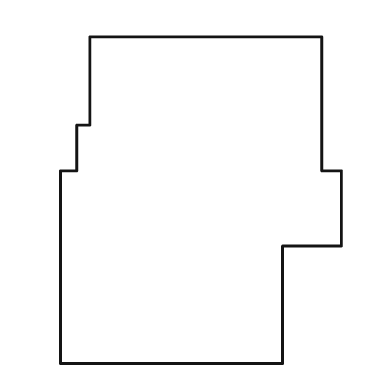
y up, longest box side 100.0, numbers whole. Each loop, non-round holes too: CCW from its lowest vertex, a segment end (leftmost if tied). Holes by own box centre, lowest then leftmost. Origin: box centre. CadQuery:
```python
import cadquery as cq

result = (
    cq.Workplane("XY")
    .moveTo(-43.0, -50.0)
    .lineTo(25.0, -50.0)
    .lineTo(25.0, -14.0)
    .lineTo(43.0, -14.0)
    .lineTo(43.0, 9.0)
    .lineTo(37.0, 9.0)
    .lineTo(37.0, 50.0)
    .lineTo(-34.0, 50.0)
    .lineTo(-34.0, 23.0)
    .lineTo(-38.0, 23.0)
    .lineTo(-38.0, 9.0)
    .lineTo(-43.0, 9.0)
    .close()
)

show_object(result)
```